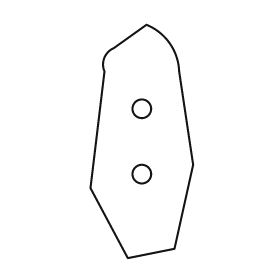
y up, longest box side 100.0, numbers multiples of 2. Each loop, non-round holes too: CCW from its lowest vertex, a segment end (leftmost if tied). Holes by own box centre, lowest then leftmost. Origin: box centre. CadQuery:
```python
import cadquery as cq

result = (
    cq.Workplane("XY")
    .moveTo(-6.0, -50.0)
    .lineTo(14.0, -46.0)
    .lineTo(22.0, -10.0)
    .lineTo(16.0, 30.0)
    .threePointArc((12.0, 42.0), (2.0, 50.0))
    .lineTo(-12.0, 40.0)
    .threePointArc((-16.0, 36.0), (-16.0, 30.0))
    .lineTo(-22.0, -20.0)
    .close()
    .moveTo(0.0, -14.0)
    .circle(4.0)
    .moveTo(0.0, 14.0)
    .circle(4.0)
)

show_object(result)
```